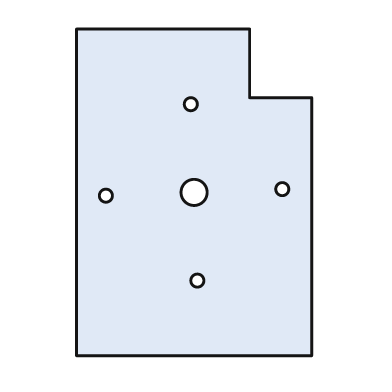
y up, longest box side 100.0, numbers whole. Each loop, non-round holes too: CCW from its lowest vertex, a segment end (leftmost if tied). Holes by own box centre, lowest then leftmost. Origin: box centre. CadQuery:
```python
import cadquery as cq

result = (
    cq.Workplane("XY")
    .moveTo(-36.0, -50.0)
    .lineTo(36.0, -50.0)
    .lineTo(36.0, 29.0)
    .lineTo(17.0, 29.0)
    .lineTo(17.0, 50.0)
    .lineTo(-36.0, 50.0)
    .close()
    .moveTo(1.0, -27.0)
    .circle(2.0)
    .moveTo(-27.0, -1.0)
    .circle(2.0)
    .moveTo(0.0, 0.0)
    .circle(4.0)
    .moveTo(27.0, 1.0)
    .circle(2.0)
    .moveTo(-1.0, 27.0)
    .circle(2.0)
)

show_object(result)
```